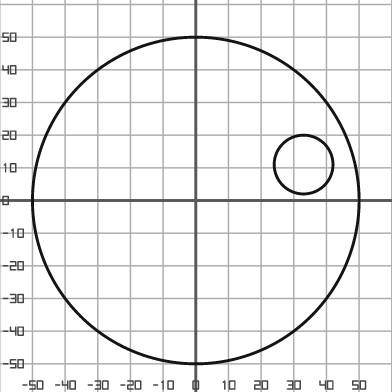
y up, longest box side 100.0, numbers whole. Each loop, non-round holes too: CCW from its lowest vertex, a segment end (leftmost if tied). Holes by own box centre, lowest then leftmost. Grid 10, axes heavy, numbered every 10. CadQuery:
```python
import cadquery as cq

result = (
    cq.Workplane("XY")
    .moveTo(0.0, 0.0)
    .circle(50.0)
    .moveTo(33.0, 11.0)
    .circle(9.0)
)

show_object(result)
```